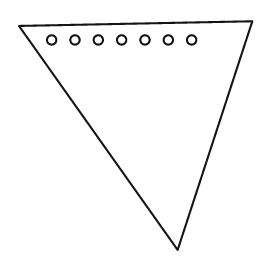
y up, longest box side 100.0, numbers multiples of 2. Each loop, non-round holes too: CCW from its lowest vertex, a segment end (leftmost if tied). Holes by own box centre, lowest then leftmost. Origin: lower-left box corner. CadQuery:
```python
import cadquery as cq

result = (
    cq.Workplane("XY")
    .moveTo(68.0, 0.0)
    .lineTo(100.0, 98.0)
    .lineTo(0.0, 96.0)
    .close()
    .moveTo(14.0, 90.0)
    .circle(2.0)
    .moveTo(24.0, 90.0)
    .circle(2.0)
    .moveTo(34.0, 90.0)
    .circle(2.0)
    .moveTo(44.0, 90.0)
    .circle(2.0)
    .moveTo(54.0, 90.0)
    .circle(2.0)
    .moveTo(64.0, 90.0)
    .circle(2.0)
    .moveTo(74.0, 90.0)
    .circle(2.0)
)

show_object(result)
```